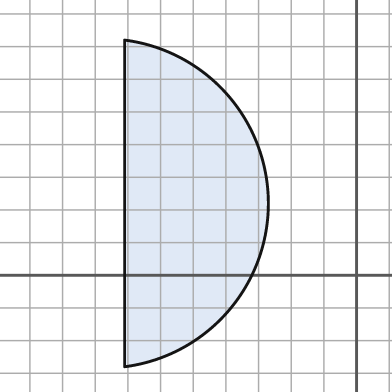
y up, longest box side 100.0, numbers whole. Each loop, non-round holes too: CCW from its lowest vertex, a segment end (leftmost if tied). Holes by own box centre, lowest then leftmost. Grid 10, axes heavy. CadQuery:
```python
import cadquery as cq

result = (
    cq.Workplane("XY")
    .moveTo(-71.0, -28.0)
    .threePointArc((-27.0, 22.0), (-71.0, 72.0))
    .close()
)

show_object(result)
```